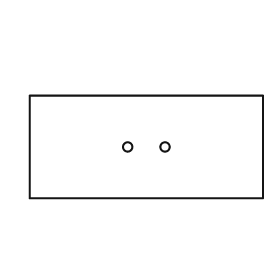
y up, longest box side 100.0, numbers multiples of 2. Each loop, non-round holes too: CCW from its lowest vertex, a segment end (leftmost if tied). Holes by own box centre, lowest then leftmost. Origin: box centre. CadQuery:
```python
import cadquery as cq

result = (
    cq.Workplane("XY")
    .moveTo(-50.0, -22.0)
    .lineTo(50.0, -22.0)
    .lineTo(50.0, 22.0)
    .lineTo(-50.0, 22.0)
    .close()
    .moveTo(-8.0, 0.0)
    .circle(2.0)
    .moveTo(8.0, 0.0)
    .circle(2.0)
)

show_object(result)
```